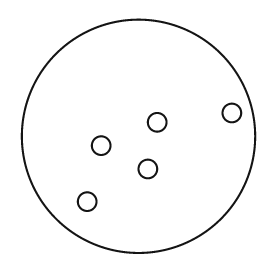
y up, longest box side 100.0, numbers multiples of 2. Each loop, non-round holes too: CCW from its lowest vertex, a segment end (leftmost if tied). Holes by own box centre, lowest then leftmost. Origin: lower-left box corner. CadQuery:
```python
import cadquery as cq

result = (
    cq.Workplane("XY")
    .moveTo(50.0, 50.0)
    .circle(50.0)
    .moveTo(28.0, 22.0)
    .circle(4.0)
    .moveTo(54.0, 36.0)
    .circle(4.0)
    .moveTo(34.0, 46.0)
    .circle(4.0)
    .moveTo(58.0, 56.0)
    .circle(4.0)
    .moveTo(90.0, 60.0)
    .circle(4.0)
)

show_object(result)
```